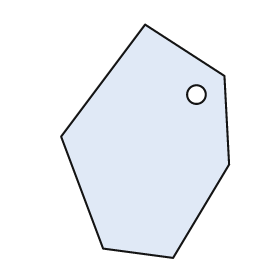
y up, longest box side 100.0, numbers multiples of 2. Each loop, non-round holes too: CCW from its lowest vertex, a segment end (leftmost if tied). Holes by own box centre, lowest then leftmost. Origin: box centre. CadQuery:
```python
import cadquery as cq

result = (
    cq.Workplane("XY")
    .moveTo(12.0, -50.0)
    .lineTo(36.0, -10.0)
    .lineTo(34.0, 28.0)
    .lineTo(0.0, 50.0)
    .lineTo(-36.0, 2.0)
    .lineTo(-18.0, -46.0)
    .close()
    .moveTo(22.0, 20.0)
    .circle(4.0)
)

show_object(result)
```